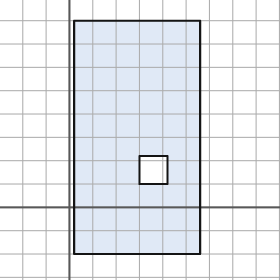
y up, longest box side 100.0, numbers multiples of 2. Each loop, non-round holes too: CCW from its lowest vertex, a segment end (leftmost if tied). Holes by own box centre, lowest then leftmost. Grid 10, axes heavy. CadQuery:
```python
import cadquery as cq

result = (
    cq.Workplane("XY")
    .moveTo(2.0, -20.0)
    .lineTo(56.0, -20.0)
    .lineTo(56.0, 80.0)
    .lineTo(2.0, 80.0)
    .close()
    .moveTo(30.0, 10.0)
    .lineTo(42.0, 10.0)
    .lineTo(42.0, 22.0)
    .lineTo(30.0, 22.0)
    .close()
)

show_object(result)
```